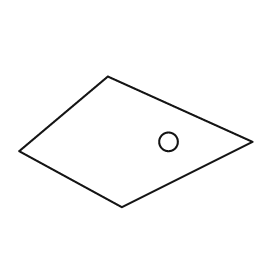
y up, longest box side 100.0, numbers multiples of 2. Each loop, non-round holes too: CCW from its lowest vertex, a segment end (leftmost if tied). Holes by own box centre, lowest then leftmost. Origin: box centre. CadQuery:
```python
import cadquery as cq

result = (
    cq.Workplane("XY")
    .moveTo(-6.0, -28.0)
    .lineTo(50.0, 0.0)
    .lineTo(-12.0, 28.0)
    .lineTo(-50.0, -4.0)
    .close()
    .moveTo(14.0, 0.0)
    .circle(4.0)
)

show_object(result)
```